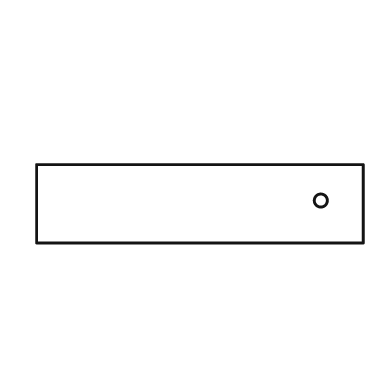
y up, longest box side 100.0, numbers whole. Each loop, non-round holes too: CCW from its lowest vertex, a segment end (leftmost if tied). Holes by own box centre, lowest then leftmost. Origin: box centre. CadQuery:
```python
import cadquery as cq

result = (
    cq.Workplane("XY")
    .moveTo(-50.0, -12.0)
    .lineTo(50.0, -12.0)
    .lineTo(50.0, 12.0)
    .lineTo(-50.0, 12.0)
    .close()
    .moveTo(37.0, 1.0)
    .circle(2.0)
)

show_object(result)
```